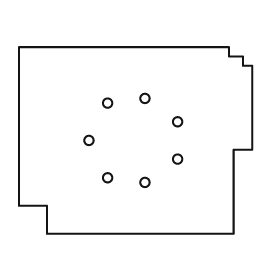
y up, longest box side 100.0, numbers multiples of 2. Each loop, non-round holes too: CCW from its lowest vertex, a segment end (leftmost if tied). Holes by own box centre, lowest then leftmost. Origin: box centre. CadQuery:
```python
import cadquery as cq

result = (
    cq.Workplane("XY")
    .moveTo(-38.0, -40.0)
    .lineTo(42.0, -40.0)
    .lineTo(42.0, -4.0)
    .lineTo(50.0, -4.0)
    .lineTo(50.0, 32.0)
    .lineTo(46.0, 32.0)
    .lineTo(46.0, 36.0)
    .lineTo(40.0, 36.0)
    .lineTo(40.0, 40.0)
    .lineTo(-50.0, 40.0)
    .lineTo(-50.0, -28.0)
    .lineTo(-38.0, -28.0)
    .close()
    .moveTo(4.0, -18.0)
    .circle(2.0)
    .moveTo(-12.0, -16.0)
    .circle(2.0)
    .moveTo(18.0, -8.0)
    .circle(2.0)
    .moveTo(-20.0, 0.0)
    .circle(2.0)
    .moveTo(18.0, 8.0)
    .circle(2.0)
    .moveTo(-12.0, 16.0)
    .circle(2.0)
    .moveTo(4.0, 18.0)
    .circle(2.0)
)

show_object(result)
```